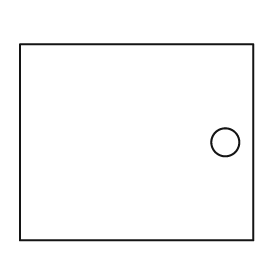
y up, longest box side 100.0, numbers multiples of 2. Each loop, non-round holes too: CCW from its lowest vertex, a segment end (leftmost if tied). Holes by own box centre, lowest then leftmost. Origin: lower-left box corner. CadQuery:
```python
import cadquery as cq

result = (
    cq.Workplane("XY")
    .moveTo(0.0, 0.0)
    .lineTo(100.0, 0.0)
    .lineTo(100.0, 84.0)
    .lineTo(0.0, 84.0)
    .close()
    .moveTo(88.0, 42.0)
    .circle(6.0)
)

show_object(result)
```